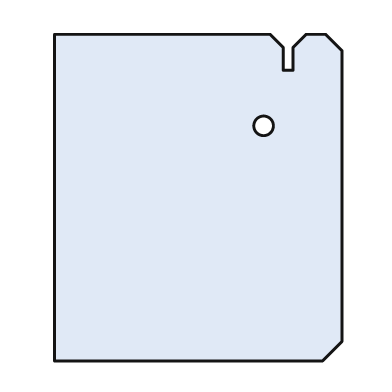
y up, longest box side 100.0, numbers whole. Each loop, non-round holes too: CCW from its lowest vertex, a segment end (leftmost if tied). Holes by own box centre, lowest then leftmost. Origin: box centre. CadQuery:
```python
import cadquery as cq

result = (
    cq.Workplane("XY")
    .moveTo(-44.0, -50.0)
    .lineTo(38.0, -50.0)
    .lineTo(44.0, -44.0)
    .lineTo(44.0, 45.0)
    .lineTo(39.0, 50.0)
    .lineTo(33.0, 50.0)
    .lineTo(29.0, 46.0)
    .lineTo(29.0, 39.0)
    .lineTo(26.0, 39.0)
    .lineTo(26.0, 46.0)
    .lineTo(22.0, 50.0)
    .lineTo(-44.0, 50.0)
    .close()
    .moveTo(20.0, 22.0)
    .circle(3.0)
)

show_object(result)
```